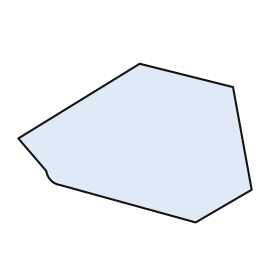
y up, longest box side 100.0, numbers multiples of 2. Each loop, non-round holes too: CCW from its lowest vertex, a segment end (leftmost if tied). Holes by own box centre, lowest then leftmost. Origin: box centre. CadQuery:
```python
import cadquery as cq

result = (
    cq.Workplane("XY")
    .moveTo(26.0, -34.0)
    .lineTo(50.0, -20.0)
    .lineTo(42.0, 24.0)
    .lineTo(2.0, 34.0)
    .lineTo(-50.0, 2.0)
    .lineTo(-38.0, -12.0)
    .threePointArc((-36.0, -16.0), (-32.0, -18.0))
    .close()
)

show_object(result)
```